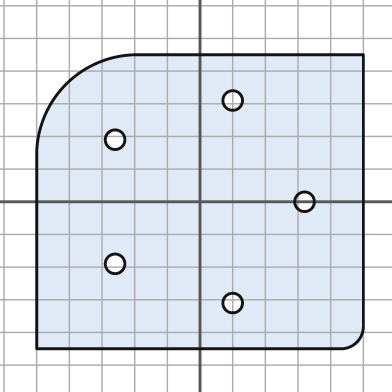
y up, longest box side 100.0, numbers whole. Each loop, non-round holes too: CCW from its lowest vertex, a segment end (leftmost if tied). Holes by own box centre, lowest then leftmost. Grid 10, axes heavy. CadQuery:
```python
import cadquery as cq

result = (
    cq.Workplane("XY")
    .moveTo(-50.0, -45.0)
    .lineTo(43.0, -45.0)
    .threePointArc((48.0, -43.0), (50.0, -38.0))
    .lineTo(50.0, 45.0)
    .lineTo(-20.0, 45.0)
    .threePointArc((-41.0, 36.0), (-50.0, 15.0))
    .close()
    .moveTo(10.0, -31.0)
    .circle(3.0)
    .moveTo(-26.0, -19.0)
    .circle(3.0)
    .moveTo(32.0, 0.0)
    .circle(3.0)
    .moveTo(-26.0, 19.0)
    .circle(3.0)
    .moveTo(10.0, 31.0)
    .circle(3.0)
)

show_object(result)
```